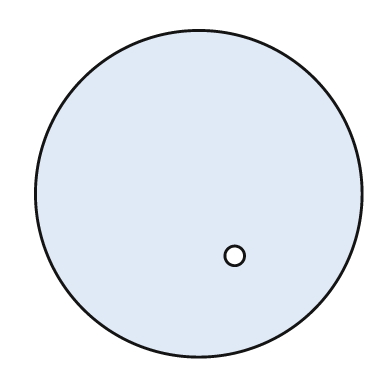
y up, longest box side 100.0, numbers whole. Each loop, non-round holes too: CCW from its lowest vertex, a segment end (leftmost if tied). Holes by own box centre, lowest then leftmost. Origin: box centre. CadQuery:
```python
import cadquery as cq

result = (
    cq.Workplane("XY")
    .moveTo(0.0, 0.0)
    .circle(50.0)
    .moveTo(11.0, -19.0)
    .circle(3.0)
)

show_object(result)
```